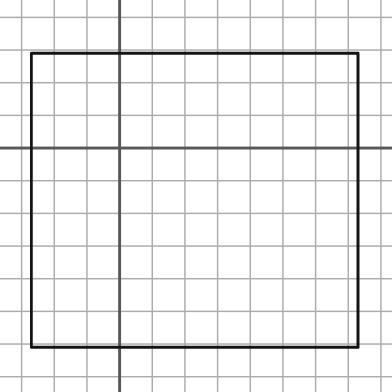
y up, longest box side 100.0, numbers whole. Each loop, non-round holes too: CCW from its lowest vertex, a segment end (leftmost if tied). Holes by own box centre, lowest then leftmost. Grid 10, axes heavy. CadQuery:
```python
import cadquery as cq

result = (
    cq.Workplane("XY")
    .moveTo(-27.0, -61.0)
    .lineTo(73.0, -61.0)
    .lineTo(73.0, 29.0)
    .lineTo(-27.0, 29.0)
    .close()
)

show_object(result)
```